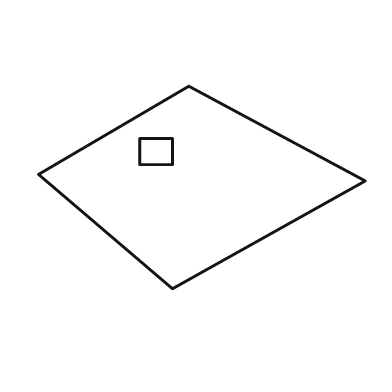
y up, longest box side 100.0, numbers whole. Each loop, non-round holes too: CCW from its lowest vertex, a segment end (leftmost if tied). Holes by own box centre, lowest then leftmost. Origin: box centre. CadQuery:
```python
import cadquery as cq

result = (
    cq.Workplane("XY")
    .moveTo(-9.0, -31.0)
    .lineTo(50.0, 2.0)
    .lineTo(-4.0, 31.0)
    .lineTo(-50.0, 4.0)
    .close()
    .moveTo(-19.0, 7.0)
    .lineTo(-9.0, 7.0)
    .lineTo(-9.0, 15.0)
    .lineTo(-19.0, 15.0)
    .close()
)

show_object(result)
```